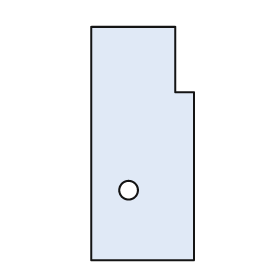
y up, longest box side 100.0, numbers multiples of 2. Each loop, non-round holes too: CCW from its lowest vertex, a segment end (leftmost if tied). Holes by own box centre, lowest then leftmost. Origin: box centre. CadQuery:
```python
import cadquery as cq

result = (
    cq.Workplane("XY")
    .moveTo(-22.0, -50.0)
    .lineTo(22.0, -50.0)
    .lineTo(22.0, 22.0)
    .lineTo(14.0, 22.0)
    .lineTo(14.0, 50.0)
    .lineTo(-22.0, 50.0)
    .close()
    .moveTo(-6.0, -20.0)
    .circle(4.0)
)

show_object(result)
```